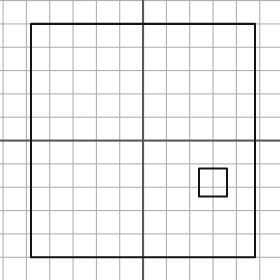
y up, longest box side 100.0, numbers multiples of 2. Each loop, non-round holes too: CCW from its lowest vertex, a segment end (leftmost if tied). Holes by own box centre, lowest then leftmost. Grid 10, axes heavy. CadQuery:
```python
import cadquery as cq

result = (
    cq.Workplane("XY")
    .moveTo(-48.0, -50.0)
    .lineTo(48.0, -50.0)
    .lineTo(48.0, 50.0)
    .lineTo(-48.0, 50.0)
    .close()
    .moveTo(24.0, -24.0)
    .lineTo(36.0, -24.0)
    .lineTo(36.0, -12.0)
    .lineTo(24.0, -12.0)
    .close()
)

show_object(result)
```